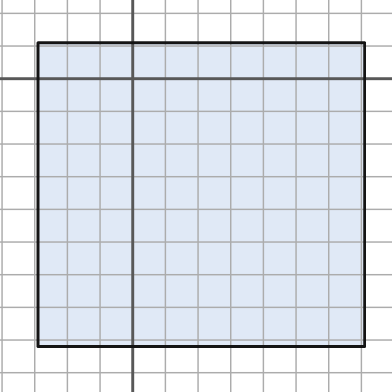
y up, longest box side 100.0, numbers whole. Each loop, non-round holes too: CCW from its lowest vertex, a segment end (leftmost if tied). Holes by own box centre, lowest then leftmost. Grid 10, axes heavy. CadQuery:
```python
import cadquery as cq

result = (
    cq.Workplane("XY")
    .moveTo(-29.0, -82.0)
    .lineTo(71.0, -82.0)
    .lineTo(71.0, 11.0)
    .lineTo(-29.0, 11.0)
    .close()
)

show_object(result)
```